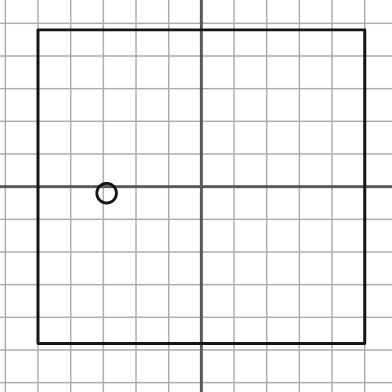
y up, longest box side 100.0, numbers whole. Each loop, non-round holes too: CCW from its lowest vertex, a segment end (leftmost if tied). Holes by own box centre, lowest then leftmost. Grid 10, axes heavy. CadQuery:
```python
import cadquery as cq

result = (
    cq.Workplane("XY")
    .moveTo(-50.0, -48.0)
    .lineTo(50.0, -48.0)
    .lineTo(50.0, 48.0)
    .lineTo(-50.0, 48.0)
    .close()
    .moveTo(-29.0, -2.0)
    .circle(3.0)
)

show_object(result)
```